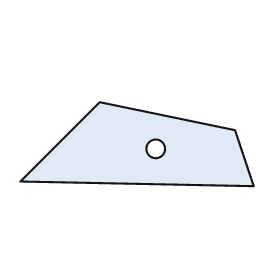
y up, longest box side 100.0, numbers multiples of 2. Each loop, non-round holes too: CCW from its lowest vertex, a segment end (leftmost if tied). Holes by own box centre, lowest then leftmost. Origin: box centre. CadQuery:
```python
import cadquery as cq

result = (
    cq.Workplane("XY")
    .moveTo(50.0, -18.0)
    .lineTo(42.0, 6.0)
    .lineTo(-16.0, 18.0)
    .lineTo(-50.0, -16.0)
    .close()
    .moveTo(8.0, -2.0)
    .circle(4.0)
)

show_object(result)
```